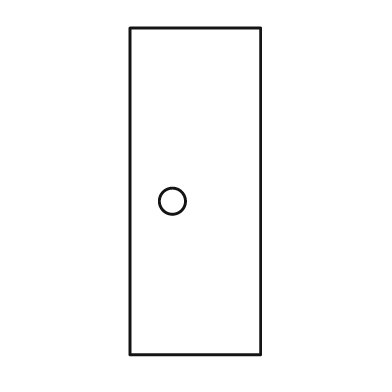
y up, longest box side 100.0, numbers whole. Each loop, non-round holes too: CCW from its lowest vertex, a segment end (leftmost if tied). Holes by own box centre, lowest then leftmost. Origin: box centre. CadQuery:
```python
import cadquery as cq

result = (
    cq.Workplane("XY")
    .moveTo(-20.0, -50.0)
    .lineTo(20.0, -50.0)
    .lineTo(20.0, 50.0)
    .lineTo(-20.0, 50.0)
    .close()
    .moveTo(-7.0, -3.0)
    .circle(4.0)
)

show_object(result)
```